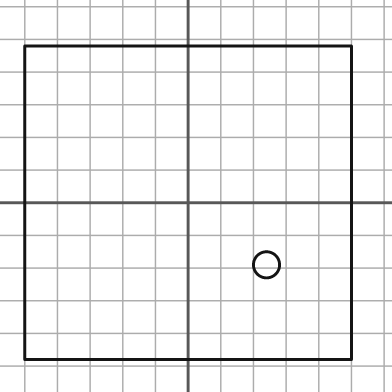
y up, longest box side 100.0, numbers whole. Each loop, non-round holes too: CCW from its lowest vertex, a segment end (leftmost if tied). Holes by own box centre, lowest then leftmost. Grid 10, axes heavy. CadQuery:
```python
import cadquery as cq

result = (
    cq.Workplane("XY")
    .moveTo(-50.0, -48.0)
    .lineTo(50.0, -48.0)
    .lineTo(50.0, 48.0)
    .lineTo(-50.0, 48.0)
    .close()
    .moveTo(24.0, -19.0)
    .circle(4.0)
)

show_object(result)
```